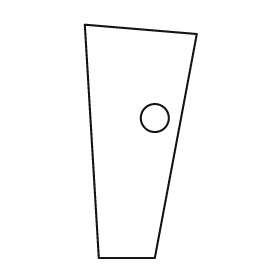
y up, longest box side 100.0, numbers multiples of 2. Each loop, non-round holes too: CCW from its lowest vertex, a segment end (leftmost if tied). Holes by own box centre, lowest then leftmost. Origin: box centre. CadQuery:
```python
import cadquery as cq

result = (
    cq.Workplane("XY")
    .moveTo(-18.0, -50.0)
    .lineTo(6.0, -50.0)
    .lineTo(24.0, 46.0)
    .lineTo(-24.0, 50.0)
    .close()
    .moveTo(6.0, 10.0)
    .circle(6.0)
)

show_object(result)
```